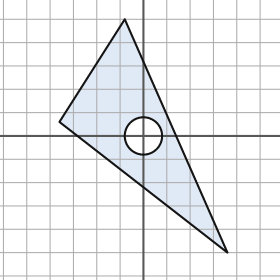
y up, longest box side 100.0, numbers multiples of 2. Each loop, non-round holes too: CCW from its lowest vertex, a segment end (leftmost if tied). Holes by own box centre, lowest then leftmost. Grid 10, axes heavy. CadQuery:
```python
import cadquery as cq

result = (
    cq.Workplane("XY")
    .moveTo(36.0, -50.0)
    .lineTo(-8.0, 50.0)
    .lineTo(-36.0, 6.0)
    .close()
    .moveTo(0.0, 0.0)
    .circle(8.0)
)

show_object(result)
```